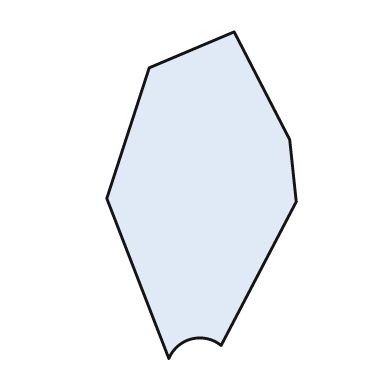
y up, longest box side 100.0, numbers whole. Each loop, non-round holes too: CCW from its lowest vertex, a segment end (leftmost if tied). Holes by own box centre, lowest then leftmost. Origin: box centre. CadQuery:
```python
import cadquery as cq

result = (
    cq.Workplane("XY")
    .moveTo(-10.0, -50.0)
    .threePointArc((-3.0, -44.0), (6.0, -46.0))
    .lineTo(29.0, -2.0)
    .lineTo(27.0, 17.0)
    .lineTo(10.0, 50.0)
    .lineTo(-16.0, 39.0)
    .lineTo(-29.0, -1.0)
    .close()
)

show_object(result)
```